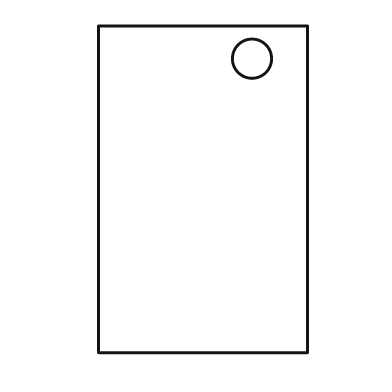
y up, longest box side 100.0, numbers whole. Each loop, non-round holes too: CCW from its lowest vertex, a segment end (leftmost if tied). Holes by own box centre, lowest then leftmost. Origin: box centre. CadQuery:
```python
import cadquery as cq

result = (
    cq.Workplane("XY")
    .moveTo(-32.0, -50.0)
    .lineTo(32.0, -50.0)
    .lineTo(32.0, 50.0)
    .lineTo(-32.0, 50.0)
    .close()
    .moveTo(15.0, 40.0)
    .circle(6.0)
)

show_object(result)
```